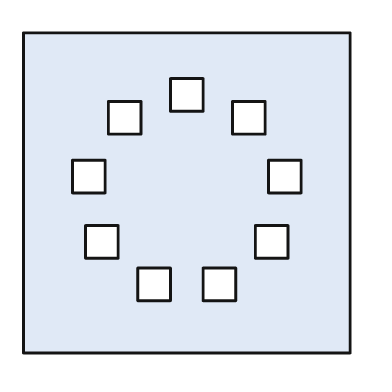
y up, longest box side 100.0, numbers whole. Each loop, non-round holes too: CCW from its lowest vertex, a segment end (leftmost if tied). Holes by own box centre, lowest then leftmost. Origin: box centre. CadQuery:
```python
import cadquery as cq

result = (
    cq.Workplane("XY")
    .moveTo(-50.0, -49.0)
    .lineTo(50.0, -49.0)
    .lineTo(50.0, 49.0)
    .lineTo(-50.0, 49.0)
    .close()
    .moveTo(-15.0, -33.0)
    .lineTo(-5.0, -33.0)
    .lineTo(-5.0, -23.0)
    .lineTo(-15.0, -23.0)
    .close()
    .moveTo(5.0, -33.0)
    .lineTo(15.0, -33.0)
    .lineTo(15.0, -23.0)
    .lineTo(5.0, -23.0)
    .close()
    .moveTo(-31.0, -20.0)
    .lineTo(-21.0, -20.0)
    .lineTo(-21.0, -10.0)
    .lineTo(-31.0, -10.0)
    .close()
    .moveTo(21.0, -20.0)
    .lineTo(31.0, -20.0)
    .lineTo(31.0, -10.0)
    .lineTo(21.0, -10.0)
    .close()
    .moveTo(-35.0, 0.0)
    .lineTo(-25.0, 0.0)
    .lineTo(-25.0, 10.0)
    .lineTo(-35.0, 10.0)
    .close()
    .moveTo(25.0, 0.0)
    .lineTo(35.0, 0.0)
    .lineTo(35.0, 10.0)
    .lineTo(25.0, 10.0)
    .close()
    .moveTo(-24.0, 18.0)
    .lineTo(-14.0, 18.0)
    .lineTo(-14.0, 28.0)
    .lineTo(-24.0, 28.0)
    .close()
    .moveTo(14.0, 18.0)
    .lineTo(24.0, 18.0)
    .lineTo(24.0, 28.0)
    .lineTo(14.0, 28.0)
    .close()
    .moveTo(-5.0, 25.0)
    .lineTo(5.0, 25.0)
    .lineTo(5.0, 35.0)
    .lineTo(-5.0, 35.0)
    .close()
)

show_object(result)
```